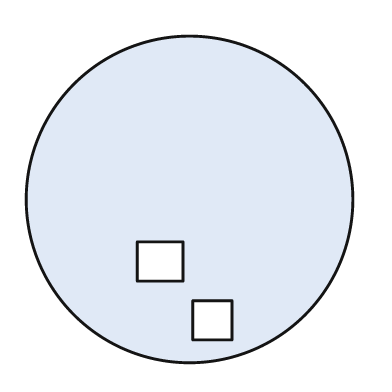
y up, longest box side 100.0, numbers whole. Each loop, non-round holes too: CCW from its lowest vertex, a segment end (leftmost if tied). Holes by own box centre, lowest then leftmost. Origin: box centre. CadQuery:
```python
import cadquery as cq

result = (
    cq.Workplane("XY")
    .moveTo(0.0, 0.0)
    .circle(50.0)
    .moveTo(1.0, -43.0)
    .lineTo(13.0, -43.0)
    .lineTo(13.0, -31.0)
    .lineTo(1.0, -31.0)
    .close()
    .moveTo(-16.0, -25.0)
    .lineTo(-2.0, -25.0)
    .lineTo(-2.0, -13.0)
    .lineTo(-16.0, -13.0)
    .close()
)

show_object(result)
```